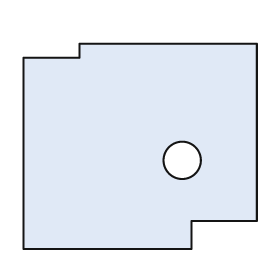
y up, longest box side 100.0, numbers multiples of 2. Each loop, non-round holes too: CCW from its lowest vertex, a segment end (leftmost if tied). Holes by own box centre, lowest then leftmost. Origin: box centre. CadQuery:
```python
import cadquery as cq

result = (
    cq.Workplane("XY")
    .moveTo(-50.0, -44.0)
    .lineTo(22.0, -44.0)
    .lineTo(22.0, -32.0)
    .lineTo(50.0, -32.0)
    .lineTo(50.0, 44.0)
    .lineTo(-26.0, 44.0)
    .lineTo(-26.0, 38.0)
    .lineTo(-50.0, 38.0)
    .close()
    .moveTo(18.0, -6.0)
    .circle(8.0)
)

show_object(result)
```